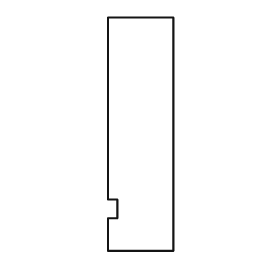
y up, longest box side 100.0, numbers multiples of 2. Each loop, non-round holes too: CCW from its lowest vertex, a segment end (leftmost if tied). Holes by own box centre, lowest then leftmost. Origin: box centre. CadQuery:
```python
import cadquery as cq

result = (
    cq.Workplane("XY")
    .moveTo(-14.0, -50.0)
    .lineTo(14.0, -50.0)
    .lineTo(14.0, 50.0)
    .lineTo(-14.0, 50.0)
    .lineTo(-14.0, -28.0)
    .lineTo(-10.0, -28.0)
    .lineTo(-10.0, -36.0)
    .lineTo(-14.0, -36.0)
    .close()
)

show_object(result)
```